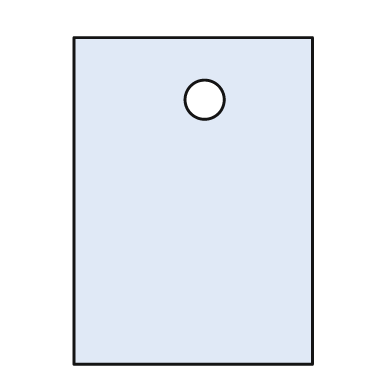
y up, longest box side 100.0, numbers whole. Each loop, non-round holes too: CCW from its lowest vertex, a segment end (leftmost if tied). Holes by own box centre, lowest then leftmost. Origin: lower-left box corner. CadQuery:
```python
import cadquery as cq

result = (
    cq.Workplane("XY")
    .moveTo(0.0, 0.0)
    .lineTo(73.0, 0.0)
    .lineTo(73.0, 100.0)
    .lineTo(0.0, 100.0)
    .close()
    .moveTo(40.0, 81.0)
    .circle(6.0)
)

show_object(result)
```